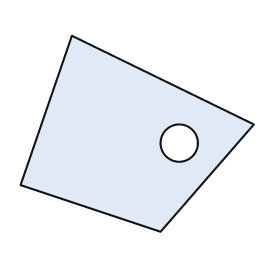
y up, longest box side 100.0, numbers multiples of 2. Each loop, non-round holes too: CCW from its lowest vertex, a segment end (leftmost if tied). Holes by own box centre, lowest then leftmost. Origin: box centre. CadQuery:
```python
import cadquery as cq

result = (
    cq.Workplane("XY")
    .moveTo(10.0, -42.0)
    .lineTo(50.0, 4.0)
    .lineTo(-28.0, 42.0)
    .lineTo(-50.0, -22.0)
    .close()
    .moveTo(18.0, -4.0)
    .circle(8.0)
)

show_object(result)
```